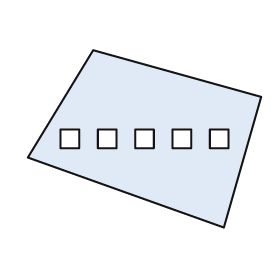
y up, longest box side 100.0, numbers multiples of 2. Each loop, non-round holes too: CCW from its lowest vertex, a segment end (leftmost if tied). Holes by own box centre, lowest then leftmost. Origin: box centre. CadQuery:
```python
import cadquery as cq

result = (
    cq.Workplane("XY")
    .moveTo(34.0, -38.0)
    .lineTo(50.0, 18.0)
    .lineTo(-22.0, 38.0)
    .lineTo(-50.0, -8.0)
    .close()
    .moveTo(-36.0, -4.0)
    .lineTo(-28.0, -4.0)
    .lineTo(-28.0, 4.0)
    .lineTo(-36.0, 4.0)
    .close()
    .moveTo(-20.0, -4.0)
    .lineTo(-12.0, -4.0)
    .lineTo(-12.0, 4.0)
    .lineTo(-20.0, 4.0)
    .close()
    .moveTo(-4.0, -4.0)
    .lineTo(4.0, -4.0)
    .lineTo(4.0, 4.0)
    .lineTo(-4.0, 4.0)
    .close()
    .moveTo(12.0, -4.0)
    .lineTo(20.0, -4.0)
    .lineTo(20.0, 4.0)
    .lineTo(12.0, 4.0)
    .close()
    .moveTo(28.0, -4.0)
    .lineTo(36.0, -4.0)
    .lineTo(36.0, 4.0)
    .lineTo(28.0, 4.0)
    .close()
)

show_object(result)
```